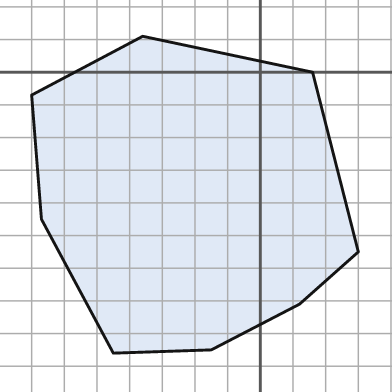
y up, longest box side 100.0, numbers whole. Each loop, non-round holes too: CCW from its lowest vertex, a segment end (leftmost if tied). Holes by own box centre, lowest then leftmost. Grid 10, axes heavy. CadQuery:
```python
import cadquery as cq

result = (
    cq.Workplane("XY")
    .moveTo(-45.0, -86.0)
    .lineTo(-15.0, -85.0)
    .lineTo(12.0, -71.0)
    .lineTo(30.0, -55.0)
    .lineTo(16.0, 0.0)
    .lineTo(-36.0, 11.0)
    .lineTo(-70.0, -7.0)
    .lineTo(-67.0, -45.0)
    .close()
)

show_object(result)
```